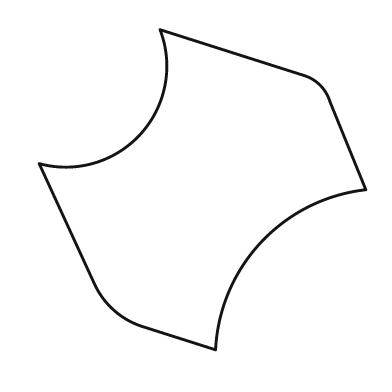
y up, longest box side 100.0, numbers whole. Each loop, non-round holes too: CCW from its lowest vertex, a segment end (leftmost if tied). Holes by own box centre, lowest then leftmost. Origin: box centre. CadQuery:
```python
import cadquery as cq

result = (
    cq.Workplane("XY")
    .moveTo(4.0, -49.0)
    .threePointArc((18.0, -16.0), (50.0, 0.0))
    .lineTo(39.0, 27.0)
    .threePointArc((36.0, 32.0), (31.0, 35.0))
    .lineTo(-13.0, 49.0)
    .threePointArc((-19.0, 17.0), (-50.0, 8.0))
    .lineTo(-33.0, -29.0)
    .threePointArc((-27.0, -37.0), (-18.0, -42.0))
    .close()
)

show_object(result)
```